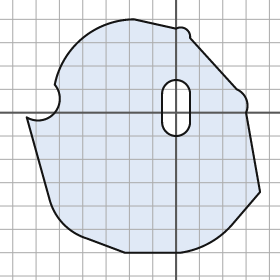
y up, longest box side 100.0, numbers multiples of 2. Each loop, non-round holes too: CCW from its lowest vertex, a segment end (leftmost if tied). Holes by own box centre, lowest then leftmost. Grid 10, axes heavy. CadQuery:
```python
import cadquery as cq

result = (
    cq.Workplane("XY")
    .moveTo(-22.0, -60.0)
    .lineTo(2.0, -60.0)
    .threePointArc((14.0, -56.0), (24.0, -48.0))
    .lineTo(36.0, -34.0)
    .lineTo(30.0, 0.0)
    .threePointArc((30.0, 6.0), (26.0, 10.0))
    .lineTo(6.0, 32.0)
    .threePointArc((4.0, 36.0), (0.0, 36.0))
    .lineTo(-18.0, 40.0)
    .threePointArc((-40.0, 32.0), (-52.0, 12.0))
    .threePointArc((-52.0, 0.0), (-64.0, -2.0))
    .lineTo(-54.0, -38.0)
    .threePointArc((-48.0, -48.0), (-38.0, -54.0))
    .close()
    .moveTo(-6.0, -4.0)
    .threePointArc((0.0, -10.0), (6.0, -4.0))
    .lineTo(6.0, 8.0)
    .threePointArc((0.0, 14.0), (-6.0, 8.0))
    .close()
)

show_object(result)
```